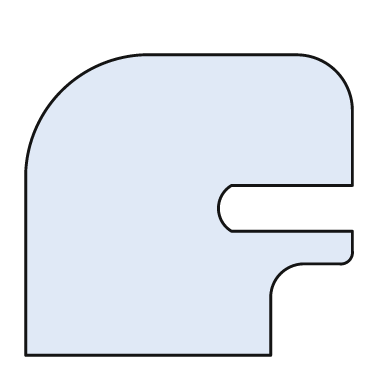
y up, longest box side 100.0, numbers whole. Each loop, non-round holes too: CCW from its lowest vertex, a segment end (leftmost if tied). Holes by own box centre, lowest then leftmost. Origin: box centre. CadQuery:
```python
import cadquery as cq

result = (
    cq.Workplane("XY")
    .moveTo(-50.0, -46.0)
    .lineTo(25.0, -46.0)
    .lineTo(25.0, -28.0)
    .threePointArc((28.0, -21.0), (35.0, -18.0))
    .lineTo(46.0, -18.0)
    .threePointArc((49.0, -17.0), (50.0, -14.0))
    .lineTo(50.0, -8.0)
    .lineTo(13.0, -8.0)
    .threePointArc((9.0, -1.0), (13.0, 6.0))
    .lineTo(50.0, 6.0)
    .lineTo(50.0, 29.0)
    .threePointArc((45.0, 41.0), (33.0, 46.0))
    .lineTo(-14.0, 46.0)
    .threePointArc((-39.0, 35.0), (-50.0, 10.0))
    .close()
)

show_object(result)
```